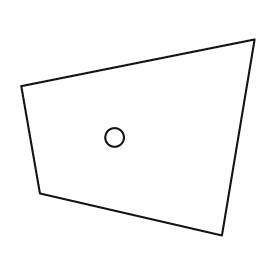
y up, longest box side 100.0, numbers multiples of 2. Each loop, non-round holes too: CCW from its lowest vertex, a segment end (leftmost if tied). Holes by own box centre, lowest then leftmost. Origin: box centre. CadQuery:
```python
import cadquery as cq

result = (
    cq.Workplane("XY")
    .moveTo(36.0, -42.0)
    .lineTo(50.0, 42.0)
    .lineTo(-50.0, 22.0)
    .lineTo(-42.0, -24.0)
    .close()
    .moveTo(-10.0, 0.0)
    .circle(4.0)
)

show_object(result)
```